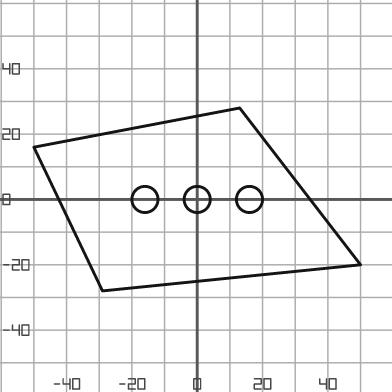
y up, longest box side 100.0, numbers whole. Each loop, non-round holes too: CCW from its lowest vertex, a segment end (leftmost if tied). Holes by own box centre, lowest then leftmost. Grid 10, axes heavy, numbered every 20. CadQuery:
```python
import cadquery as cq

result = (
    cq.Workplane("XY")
    .moveTo(-29.0, -28.0)
    .lineTo(50.0, -20.0)
    .lineTo(13.0, 28.0)
    .lineTo(-50.0, 16.0)
    .close()
    .moveTo(-16.0, 0.0)
    .circle(4.0)
    .moveTo(0.0, 0.0)
    .circle(4.0)
    .moveTo(16.0, 0.0)
    .circle(4.0)
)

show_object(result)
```